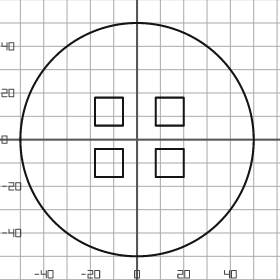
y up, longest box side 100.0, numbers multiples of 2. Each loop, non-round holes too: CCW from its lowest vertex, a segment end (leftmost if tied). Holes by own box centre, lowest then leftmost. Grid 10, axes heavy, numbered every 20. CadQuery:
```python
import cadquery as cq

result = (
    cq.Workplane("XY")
    .moveTo(0.0, 0.0)
    .circle(50.0)
    .moveTo(-18.0, -16.0)
    .lineTo(-6.0, -16.0)
    .lineTo(-6.0, -4.0)
    .lineTo(-18.0, -4.0)
    .close()
    .moveTo(8.0, -16.0)
    .lineTo(20.0, -16.0)
    .lineTo(20.0, -4.0)
    .lineTo(8.0, -4.0)
    .close()
    .moveTo(-18.0, 6.0)
    .lineTo(-6.0, 6.0)
    .lineTo(-6.0, 18.0)
    .lineTo(-18.0, 18.0)
    .close()
    .moveTo(8.0, 6.0)
    .lineTo(20.0, 6.0)
    .lineTo(20.0, 18.0)
    .lineTo(8.0, 18.0)
    .close()
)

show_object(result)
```